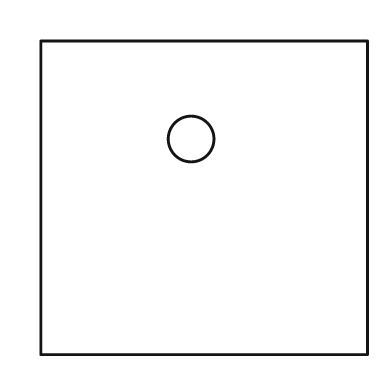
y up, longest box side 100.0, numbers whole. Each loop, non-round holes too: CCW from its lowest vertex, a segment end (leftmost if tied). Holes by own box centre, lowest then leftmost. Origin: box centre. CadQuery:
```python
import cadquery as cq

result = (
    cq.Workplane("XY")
    .moveTo(-50.0, -48.0)
    .lineTo(50.0, -48.0)
    .lineTo(50.0, 48.0)
    .lineTo(-50.0, 48.0)
    .close()
    .moveTo(-4.0, 18.0)
    .circle(7.0)
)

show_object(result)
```